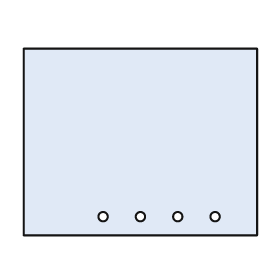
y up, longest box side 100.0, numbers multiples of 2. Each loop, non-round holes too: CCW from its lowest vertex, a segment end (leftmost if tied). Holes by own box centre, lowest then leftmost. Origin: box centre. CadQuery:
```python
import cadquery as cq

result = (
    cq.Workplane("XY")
    .moveTo(-50.0, -40.0)
    .lineTo(50.0, -40.0)
    .lineTo(50.0, 40.0)
    .lineTo(-50.0, 40.0)
    .close()
    .moveTo(-16.0, -32.0)
    .circle(2.0)
    .moveTo(0.0, -32.0)
    .circle(2.0)
    .moveTo(16.0, -32.0)
    .circle(2.0)
    .moveTo(32.0, -32.0)
    .circle(2.0)
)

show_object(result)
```